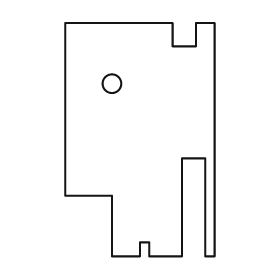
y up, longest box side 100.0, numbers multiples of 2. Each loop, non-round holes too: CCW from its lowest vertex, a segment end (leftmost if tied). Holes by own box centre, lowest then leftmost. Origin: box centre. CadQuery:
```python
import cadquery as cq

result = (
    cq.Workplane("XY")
    .moveTo(-12.0, -50.0)
    .lineTo(0.0, -50.0)
    .lineTo(0.0, -44.0)
    .lineTo(4.0, -44.0)
    .lineTo(4.0, -50.0)
    .lineTo(18.0, -50.0)
    .lineTo(18.0, -8.0)
    .lineTo(28.0, -8.0)
    .lineTo(28.0, -50.0)
    .lineTo(32.0, -50.0)
    .lineTo(32.0, 50.0)
    .lineTo(24.0, 50.0)
    .lineTo(24.0, 40.0)
    .lineTo(14.0, 40.0)
    .lineTo(14.0, 50.0)
    .lineTo(-32.0, 50.0)
    .lineTo(-32.0, -24.0)
    .lineTo(-12.0, -24.0)
    .close()
    .moveTo(-12.0, 24.0)
    .circle(4.0)
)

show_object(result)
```